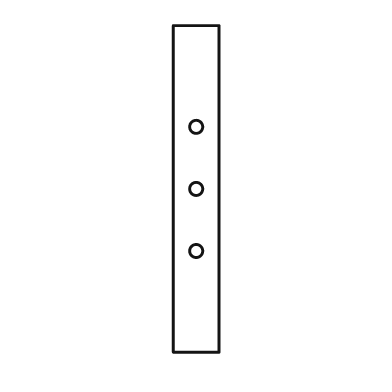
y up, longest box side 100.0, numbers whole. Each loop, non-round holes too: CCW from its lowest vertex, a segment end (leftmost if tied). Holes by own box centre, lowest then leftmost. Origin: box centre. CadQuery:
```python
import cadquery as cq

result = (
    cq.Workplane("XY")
    .moveTo(-7.0, -50.0)
    .lineTo(7.0, -50.0)
    .lineTo(7.0, 50.0)
    .lineTo(-7.0, 50.0)
    .close()
    .moveTo(0.0, -19.0)
    .circle(2.0)
    .moveTo(0.0, 0.0)
    .circle(2.0)
    .moveTo(0.0, 19.0)
    .circle(2.0)
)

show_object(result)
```